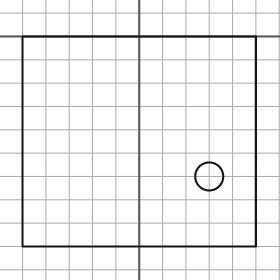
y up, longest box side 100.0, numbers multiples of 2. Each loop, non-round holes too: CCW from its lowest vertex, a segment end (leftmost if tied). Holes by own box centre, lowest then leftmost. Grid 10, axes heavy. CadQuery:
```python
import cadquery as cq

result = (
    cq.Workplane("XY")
    .moveTo(-50.0, -90.0)
    .lineTo(50.0, -90.0)
    .lineTo(50.0, 0.0)
    .lineTo(-50.0, 0.0)
    .close()
    .moveTo(30.0, -60.0)
    .circle(6.0)
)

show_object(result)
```